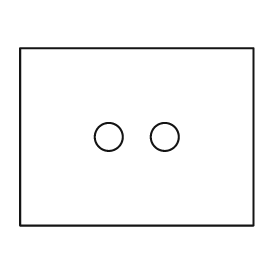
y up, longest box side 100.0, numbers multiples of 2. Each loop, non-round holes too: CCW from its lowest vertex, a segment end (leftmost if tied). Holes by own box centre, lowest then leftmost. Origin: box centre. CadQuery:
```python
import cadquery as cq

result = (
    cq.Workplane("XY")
    .moveTo(-50.0, -38.0)
    .lineTo(50.0, -38.0)
    .lineTo(50.0, 38.0)
    .lineTo(-50.0, 38.0)
    .close()
    .moveTo(-12.0, 0.0)
    .circle(6.0)
    .moveTo(12.0, 0.0)
    .circle(6.0)
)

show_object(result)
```